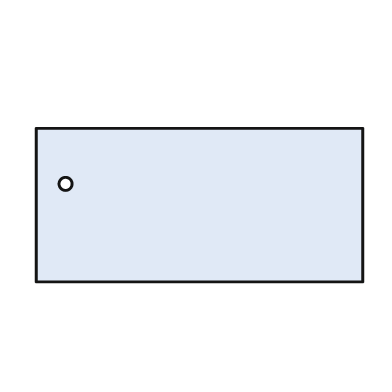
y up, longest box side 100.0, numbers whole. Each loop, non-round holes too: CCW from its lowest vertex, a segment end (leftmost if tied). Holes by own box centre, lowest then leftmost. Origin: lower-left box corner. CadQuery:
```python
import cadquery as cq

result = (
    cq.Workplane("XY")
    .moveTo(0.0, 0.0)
    .lineTo(100.0, 0.0)
    .lineTo(100.0, 47.0)
    .lineTo(0.0, 47.0)
    .close()
    .moveTo(9.0, 30.0)
    .circle(2.0)
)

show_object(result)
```